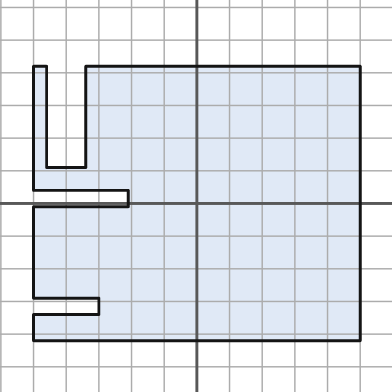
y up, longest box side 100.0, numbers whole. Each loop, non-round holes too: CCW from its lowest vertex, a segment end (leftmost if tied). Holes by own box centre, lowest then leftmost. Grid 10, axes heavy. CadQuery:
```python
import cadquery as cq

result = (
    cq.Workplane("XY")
    .moveTo(-50.0, -42.0)
    .lineTo(50.0, -42.0)
    .lineTo(50.0, 42.0)
    .lineTo(-34.0, 42.0)
    .lineTo(-34.0, 11.0)
    .lineTo(-46.0, 11.0)
    .lineTo(-46.0, 42.0)
    .lineTo(-50.0, 42.0)
    .lineTo(-50.0, 4.0)
    .lineTo(-21.0, 4.0)
    .lineTo(-21.0, -1.0)
    .lineTo(-50.0, -1.0)
    .lineTo(-50.0, -29.0)
    .lineTo(-30.0, -29.0)
    .lineTo(-30.0, -34.0)
    .lineTo(-50.0, -34.0)
    .close()
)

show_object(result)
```